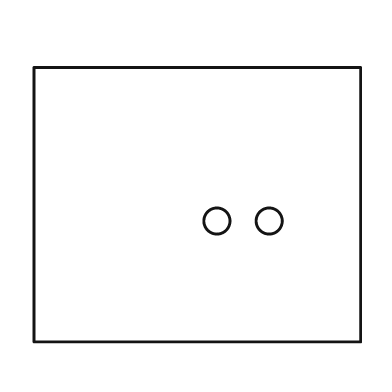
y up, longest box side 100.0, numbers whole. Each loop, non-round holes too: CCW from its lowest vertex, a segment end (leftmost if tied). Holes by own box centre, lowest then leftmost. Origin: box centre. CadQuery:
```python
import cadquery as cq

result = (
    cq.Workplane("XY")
    .moveTo(-50.0, -42.0)
    .lineTo(50.0, -42.0)
    .lineTo(50.0, 42.0)
    .lineTo(-50.0, 42.0)
    .close()
    .moveTo(6.0, -5.0)
    .circle(4.0)
    .moveTo(22.0, -5.0)
    .circle(4.0)
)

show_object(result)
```